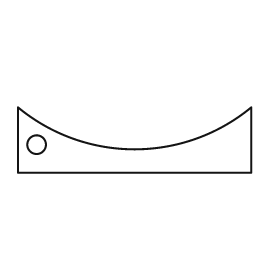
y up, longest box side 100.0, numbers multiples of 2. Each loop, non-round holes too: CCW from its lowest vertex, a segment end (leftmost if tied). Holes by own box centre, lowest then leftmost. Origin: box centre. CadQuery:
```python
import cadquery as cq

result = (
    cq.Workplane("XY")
    .moveTo(-50.0, -14.0)
    .lineTo(50.0, -14.0)
    .lineTo(50.0, 14.0)
    .threePointArc((0.0, -4.0), (-50.0, 14.0))
    .close()
    .moveTo(-42.0, -2.0)
    .circle(4.0)
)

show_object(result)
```